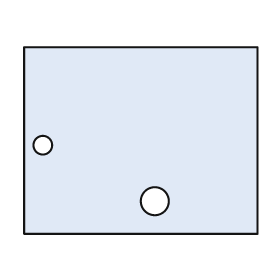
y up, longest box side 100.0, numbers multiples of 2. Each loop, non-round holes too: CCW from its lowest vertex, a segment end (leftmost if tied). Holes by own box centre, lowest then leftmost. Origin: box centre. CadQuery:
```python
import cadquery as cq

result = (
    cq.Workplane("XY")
    .moveTo(-50.0, -40.0)
    .lineTo(50.0, -40.0)
    .lineTo(50.0, 40.0)
    .lineTo(-50.0, 40.0)
    .close()
    .moveTo(6.0, -26.0)
    .circle(6.0)
    .moveTo(-42.0, -2.0)
    .circle(4.0)
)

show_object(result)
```